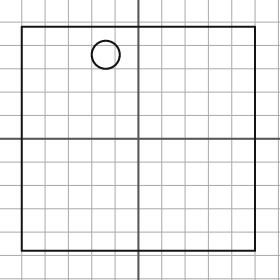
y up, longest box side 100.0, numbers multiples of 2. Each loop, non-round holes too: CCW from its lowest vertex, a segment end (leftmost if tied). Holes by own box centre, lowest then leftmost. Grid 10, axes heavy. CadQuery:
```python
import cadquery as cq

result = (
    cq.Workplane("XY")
    .moveTo(-50.0, -48.0)
    .lineTo(50.0, -48.0)
    .lineTo(50.0, 48.0)
    .lineTo(-50.0, 48.0)
    .close()
    .moveTo(-14.0, 36.0)
    .circle(6.0)
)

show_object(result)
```